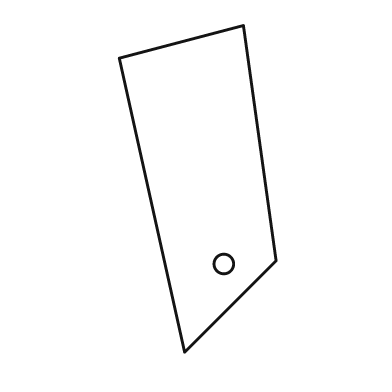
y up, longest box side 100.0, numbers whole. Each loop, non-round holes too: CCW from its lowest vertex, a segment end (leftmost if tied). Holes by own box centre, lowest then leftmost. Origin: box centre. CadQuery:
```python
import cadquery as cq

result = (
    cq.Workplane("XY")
    .moveTo(-4.0, -50.0)
    .lineTo(24.0, -22.0)
    .lineTo(14.0, 50.0)
    .lineTo(-24.0, 40.0)
    .close()
    .moveTo(8.0, -23.0)
    .circle(3.0)
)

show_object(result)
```